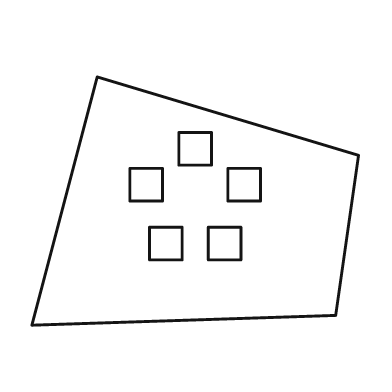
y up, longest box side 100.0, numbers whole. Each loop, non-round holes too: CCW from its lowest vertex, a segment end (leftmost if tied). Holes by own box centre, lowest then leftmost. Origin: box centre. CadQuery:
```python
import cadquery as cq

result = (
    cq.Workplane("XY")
    .moveTo(-50.0, -38.0)
    .lineTo(43.0, -35.0)
    .lineTo(50.0, 14.0)
    .lineTo(-30.0, 38.0)
    .close()
    .moveTo(-14.0, -18.0)
    .lineTo(-4.0, -18.0)
    .lineTo(-4.0, -8.0)
    .lineTo(-14.0, -8.0)
    .close()
    .moveTo(4.0, -18.0)
    .lineTo(14.0, -18.0)
    .lineTo(14.0, -8.0)
    .lineTo(4.0, -8.0)
    .close()
    .moveTo(-20.0, 0.0)
    .lineTo(-10.0, 0.0)
    .lineTo(-10.0, 10.0)
    .lineTo(-20.0, 10.0)
    .close()
    .moveTo(10.0, 0.0)
    .lineTo(20.0, 0.0)
    .lineTo(20.0, 10.0)
    .lineTo(10.0, 10.0)
    .close()
    .moveTo(-5.0, 11.0)
    .lineTo(5.0, 11.0)
    .lineTo(5.0, 21.0)
    .lineTo(-5.0, 21.0)
    .close()
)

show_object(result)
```